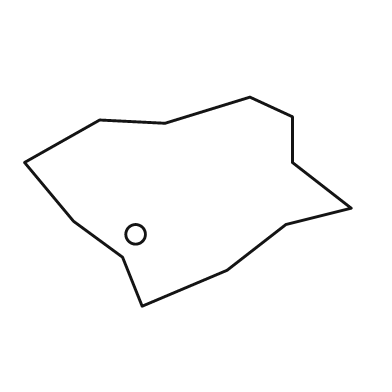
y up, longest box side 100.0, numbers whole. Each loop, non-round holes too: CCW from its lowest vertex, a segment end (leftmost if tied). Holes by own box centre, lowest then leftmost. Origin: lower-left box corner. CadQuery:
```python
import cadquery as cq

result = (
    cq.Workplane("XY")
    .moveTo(36.0, 0.0)
    .lineTo(62.0, 11.0)
    .lineTo(80.0, 25.0)
    .lineTo(100.0, 30.0)
    .lineTo(82.0, 44.0)
    .lineTo(82.0, 58.0)
    .lineTo(69.0, 64.0)
    .lineTo(43.0, 56.0)
    .lineTo(23.0, 57.0)
    .lineTo(0.0, 44.0)
    .lineTo(15.0, 26.0)
    .lineTo(30.0, 15.0)
    .close()
    .moveTo(34.0, 22.0)
    .circle(3.0)
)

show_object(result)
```